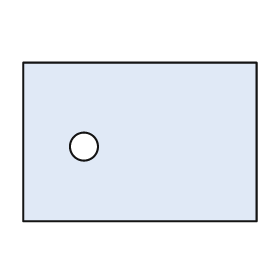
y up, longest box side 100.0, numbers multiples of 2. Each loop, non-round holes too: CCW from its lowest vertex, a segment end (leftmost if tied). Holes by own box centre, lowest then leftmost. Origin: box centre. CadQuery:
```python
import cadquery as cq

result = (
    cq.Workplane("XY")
    .moveTo(-50.0, -34.0)
    .lineTo(50.0, -34.0)
    .lineTo(50.0, 34.0)
    .lineTo(-50.0, 34.0)
    .close()
    .moveTo(-24.0, -2.0)
    .circle(6.0)
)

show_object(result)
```